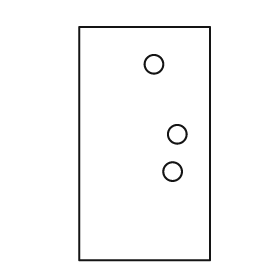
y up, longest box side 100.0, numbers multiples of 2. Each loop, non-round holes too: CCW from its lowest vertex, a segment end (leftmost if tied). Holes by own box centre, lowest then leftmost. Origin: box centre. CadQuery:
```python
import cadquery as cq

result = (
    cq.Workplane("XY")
    .moveTo(-28.0, -50.0)
    .lineTo(28.0, -50.0)
    .lineTo(28.0, 50.0)
    .lineTo(-28.0, 50.0)
    .close()
    .moveTo(12.0, -12.0)
    .circle(4.0)
    .moveTo(14.0, 4.0)
    .circle(4.0)
    .moveTo(4.0, 34.0)
    .circle(4.0)
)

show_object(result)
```